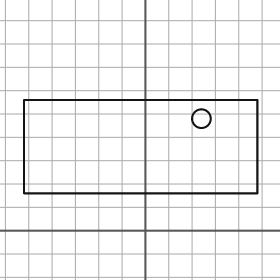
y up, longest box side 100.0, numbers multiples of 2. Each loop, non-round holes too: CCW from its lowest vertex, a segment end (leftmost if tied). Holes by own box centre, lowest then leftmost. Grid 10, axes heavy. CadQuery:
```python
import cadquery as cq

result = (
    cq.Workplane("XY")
    .moveTo(-52.0, 16.0)
    .lineTo(48.0, 16.0)
    .lineTo(48.0, 56.0)
    .lineTo(-52.0, 56.0)
    .close()
    .moveTo(24.0, 48.0)
    .circle(4.0)
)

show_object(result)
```